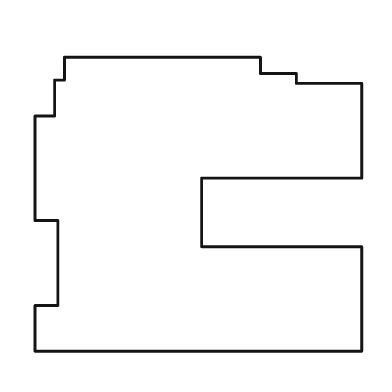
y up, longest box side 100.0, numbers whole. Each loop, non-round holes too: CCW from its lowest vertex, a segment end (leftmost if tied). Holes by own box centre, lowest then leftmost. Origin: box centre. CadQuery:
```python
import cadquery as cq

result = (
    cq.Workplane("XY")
    .moveTo(-50.0, -45.0)
    .lineTo(50.0, -45.0)
    .lineTo(50.0, -13.0)
    .lineTo(1.0, -13.0)
    .lineTo(1.0, 8.0)
    .lineTo(50.0, 8.0)
    .lineTo(50.0, 37.0)
    .lineTo(30.0, 37.0)
    .lineTo(30.0, 40.0)
    .lineTo(19.0, 40.0)
    .lineTo(19.0, 45.0)
    .lineTo(-41.0, 45.0)
    .lineTo(-41.0, 38.0)
    .lineTo(-44.0, 38.0)
    .lineTo(-44.0, 27.0)
    .lineTo(-50.0, 27.0)
    .lineTo(-50.0, -5.0)
    .lineTo(-43.0, -5.0)
    .lineTo(-43.0, -31.0)
    .lineTo(-50.0, -31.0)
    .close()
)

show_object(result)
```